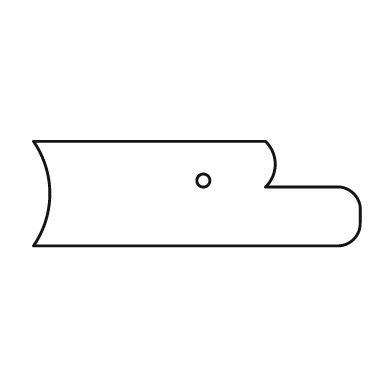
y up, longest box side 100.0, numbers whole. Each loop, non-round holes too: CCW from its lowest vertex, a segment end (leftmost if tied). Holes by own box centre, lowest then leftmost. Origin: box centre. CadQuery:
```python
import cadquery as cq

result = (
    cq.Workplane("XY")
    .moveTo(-50.0, -16.0)
    .lineTo(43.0, -16.0)
    .threePointArc((48.0, -14.0), (50.0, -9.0))
    .lineTo(50.0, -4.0)
    .threePointArc((48.0, 0.0), (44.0, 2.0))
    .lineTo(21.0, 2.0)
    .threePointArc((24.0, 9.0), (21.0, 16.0))
    .lineTo(-50.0, 16.0)
    .threePointArc((-45.0, 0.0), (-50.0, -16.0))
    .close()
    .moveTo(2.0, 4.0)
    .circle(2.0)
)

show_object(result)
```